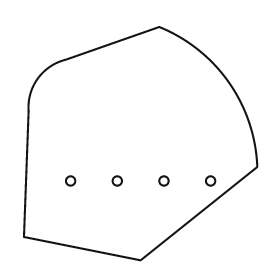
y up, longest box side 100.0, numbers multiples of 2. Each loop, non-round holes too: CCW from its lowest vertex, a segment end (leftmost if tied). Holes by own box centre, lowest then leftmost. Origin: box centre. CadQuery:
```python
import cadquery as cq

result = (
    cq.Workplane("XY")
    .moveTo(0.0, -50.0)
    .lineTo(50.0, -10.0)
    .threePointArc((38.0, 26.0), (8.0, 50.0))
    .lineTo(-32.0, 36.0)
    .threePointArc((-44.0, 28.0), (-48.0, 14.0))
    .lineTo(-50.0, -40.0)
    .close()
    .moveTo(-30.0, -16.0)
    .circle(2.0)
    .moveTo(-10.0, -16.0)
    .circle(2.0)
    .moveTo(10.0, -16.0)
    .circle(2.0)
    .moveTo(30.0, -16.0)
    .circle(2.0)
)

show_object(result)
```